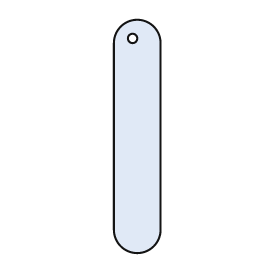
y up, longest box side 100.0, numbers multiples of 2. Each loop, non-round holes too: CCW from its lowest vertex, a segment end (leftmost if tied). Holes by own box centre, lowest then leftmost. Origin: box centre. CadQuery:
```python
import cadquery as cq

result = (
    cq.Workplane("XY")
    .moveTo(-10.0, -40.0)
    .threePointArc((0.0, -50.0), (10.0, -40.0))
    .lineTo(10.0, 40.0)
    .threePointArc((0.0, 50.0), (-10.0, 40.0))
    .close()
    .moveTo(-2.0, 42.0)
    .circle(2.0)
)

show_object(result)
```